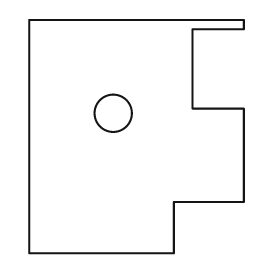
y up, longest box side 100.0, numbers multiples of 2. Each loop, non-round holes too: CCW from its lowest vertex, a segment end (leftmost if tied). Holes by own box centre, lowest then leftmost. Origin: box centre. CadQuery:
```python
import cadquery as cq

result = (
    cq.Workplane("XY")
    .moveTo(-46.0, -50.0)
    .lineTo(16.0, -50.0)
    .lineTo(16.0, -28.0)
    .lineTo(46.0, -28.0)
    .lineTo(46.0, 12.0)
    .lineTo(24.0, 12.0)
    .lineTo(24.0, 46.0)
    .lineTo(46.0, 46.0)
    .lineTo(46.0, 50.0)
    .lineTo(-46.0, 50.0)
    .close()
    .moveTo(-10.0, 10.0)
    .circle(8.0)
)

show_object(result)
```